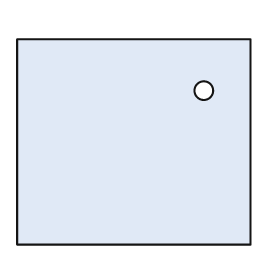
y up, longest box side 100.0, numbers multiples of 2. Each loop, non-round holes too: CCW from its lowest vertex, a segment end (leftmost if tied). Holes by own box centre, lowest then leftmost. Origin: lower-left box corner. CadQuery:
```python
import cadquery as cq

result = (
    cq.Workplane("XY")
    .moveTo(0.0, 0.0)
    .lineTo(100.0, 0.0)
    .lineTo(100.0, 88.0)
    .lineTo(0.0, 88.0)
    .close()
    .moveTo(80.0, 66.0)
    .circle(4.0)
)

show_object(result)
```